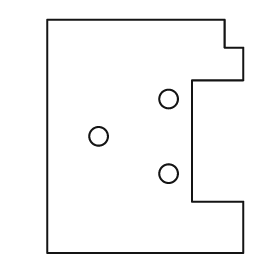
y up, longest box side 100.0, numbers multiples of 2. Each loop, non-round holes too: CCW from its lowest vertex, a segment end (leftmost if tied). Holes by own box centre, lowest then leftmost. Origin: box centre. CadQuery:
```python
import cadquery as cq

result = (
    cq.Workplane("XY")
    .moveTo(-42.0, -50.0)
    .lineTo(42.0, -50.0)
    .lineTo(42.0, -28.0)
    .lineTo(20.0, -28.0)
    .lineTo(20.0, 24.0)
    .lineTo(42.0, 24.0)
    .lineTo(42.0, 38.0)
    .lineTo(34.0, 38.0)
    .lineTo(34.0, 50.0)
    .lineTo(-42.0, 50.0)
    .close()
    .moveTo(10.0, -16.0)
    .circle(4.0)
    .moveTo(-20.0, 0.0)
    .circle(4.0)
    .moveTo(10.0, 16.0)
    .circle(4.0)
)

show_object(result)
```